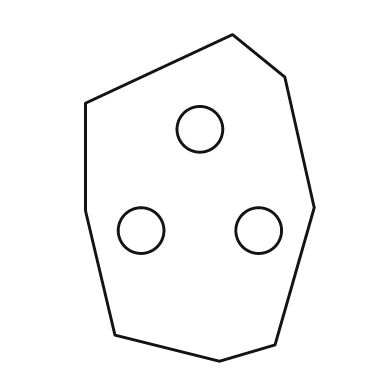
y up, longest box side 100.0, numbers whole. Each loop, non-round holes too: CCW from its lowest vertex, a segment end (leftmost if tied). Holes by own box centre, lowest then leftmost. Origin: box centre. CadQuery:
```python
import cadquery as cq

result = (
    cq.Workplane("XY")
    .moveTo(6.0, -50.0)
    .lineTo(23.0, -45.0)
    .lineTo(35.0, -3.0)
    .lineTo(26.0, 37.0)
    .lineTo(10.0, 50.0)
    .lineTo(-35.0, 29.0)
    .lineTo(-35.0, -4.0)
    .lineTo(-26.0, -42.0)
    .close()
    .moveTo(-18.0, -10.0)
    .circle(7.0)
    .moveTo(18.0, -10.0)
    .circle(7.0)
    .moveTo(0.0, 21.0)
    .circle(7.0)
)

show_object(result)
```